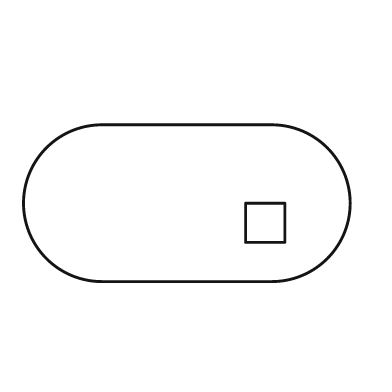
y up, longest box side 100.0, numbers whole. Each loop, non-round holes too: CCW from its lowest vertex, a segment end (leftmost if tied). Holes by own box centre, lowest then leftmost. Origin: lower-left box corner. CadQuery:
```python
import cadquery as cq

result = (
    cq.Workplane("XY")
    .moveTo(24.0, 0.0)
    .lineTo(76.0, 0.0)
    .threePointArc((100.0, 24.0), (76.0, 48.0))
    .lineTo(24.0, 48.0)
    .threePointArc((0.0, 24.0), (24.0, 0.0))
    .close()
    .moveTo(68.0, 12.0)
    .lineTo(80.0, 12.0)
    .lineTo(80.0, 24.0)
    .lineTo(68.0, 24.0)
    .close()
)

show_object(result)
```